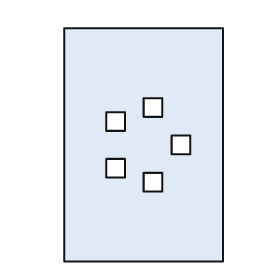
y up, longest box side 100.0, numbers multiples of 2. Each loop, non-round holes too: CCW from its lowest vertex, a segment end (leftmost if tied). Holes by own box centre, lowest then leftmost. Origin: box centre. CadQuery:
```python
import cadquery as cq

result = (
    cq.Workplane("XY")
    .moveTo(-34.0, -50.0)
    .lineTo(34.0, -50.0)
    .lineTo(34.0, 50.0)
    .lineTo(-34.0, 50.0)
    .close()
    .moveTo(0.0, -20.0)
    .lineTo(8.0, -20.0)
    .lineTo(8.0, -12.0)
    .lineTo(0.0, -12.0)
    .close()
    .moveTo(-16.0, -14.0)
    .lineTo(-8.0, -14.0)
    .lineTo(-8.0, -6.0)
    .lineTo(-16.0, -6.0)
    .close()
    .moveTo(12.0, -4.0)
    .lineTo(20.0, -4.0)
    .lineTo(20.0, 4.0)
    .lineTo(12.0, 4.0)
    .close()
    .moveTo(-16.0, 6.0)
    .lineTo(-8.0, 6.0)
    .lineTo(-8.0, 14.0)
    .lineTo(-16.0, 14.0)
    .close()
    .moveTo(0.0, 12.0)
    .lineTo(8.0, 12.0)
    .lineTo(8.0, 20.0)
    .lineTo(0.0, 20.0)
    .close()
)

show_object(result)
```